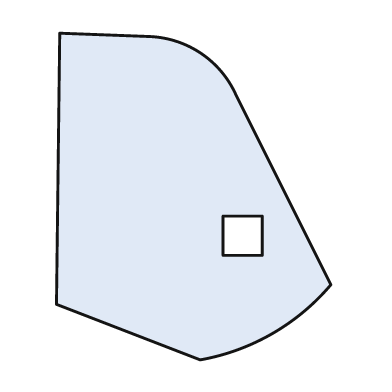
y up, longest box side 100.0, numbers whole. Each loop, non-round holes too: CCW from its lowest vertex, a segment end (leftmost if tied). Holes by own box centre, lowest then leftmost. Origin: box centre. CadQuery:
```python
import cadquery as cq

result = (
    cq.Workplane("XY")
    .moveTo(2.0, -50.0)
    .threePointArc((24.0, -42.0), (42.0, -27.0))
    .lineTo(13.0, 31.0)
    .threePointArc((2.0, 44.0), (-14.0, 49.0))
    .lineTo(-41.0, 50.0)
    .lineTo(-42.0, -33.0)
    .close()
    .moveTo(9.0, -18.0)
    .lineTo(21.0, -18.0)
    .lineTo(21.0, -6.0)
    .lineTo(9.0, -6.0)
    .close()
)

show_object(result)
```